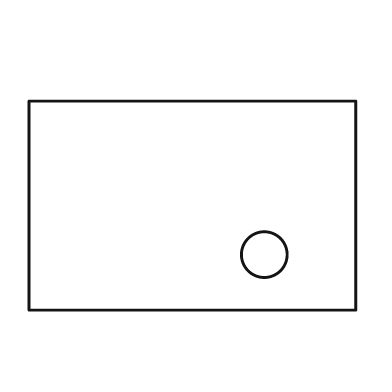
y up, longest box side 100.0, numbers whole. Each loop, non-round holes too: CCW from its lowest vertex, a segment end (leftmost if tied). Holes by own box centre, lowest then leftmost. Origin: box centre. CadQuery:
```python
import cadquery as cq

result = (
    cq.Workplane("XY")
    .moveTo(-50.0, -32.0)
    .lineTo(50.0, -32.0)
    .lineTo(50.0, 32.0)
    .lineTo(-50.0, 32.0)
    .close()
    .moveTo(22.0, -15.0)
    .circle(7.0)
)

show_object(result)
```